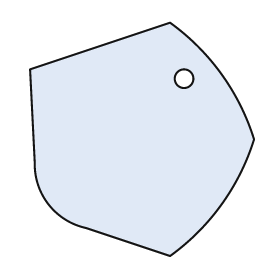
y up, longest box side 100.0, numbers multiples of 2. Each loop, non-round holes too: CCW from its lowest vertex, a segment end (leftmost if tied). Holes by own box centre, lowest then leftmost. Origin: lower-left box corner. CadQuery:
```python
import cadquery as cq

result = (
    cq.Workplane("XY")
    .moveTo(60.0, 0.0)
    .threePointArc((82.0, 22.0), (96.0, 50.0))
    .threePointArc((82.0, 78.0), (60.0, 100.0))
    .lineTo(0.0, 80.0)
    .lineTo(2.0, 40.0)
    .threePointArc((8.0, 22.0), (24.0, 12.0))
    .close()
    .moveTo(66.0, 76.0)
    .circle(4.0)
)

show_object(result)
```